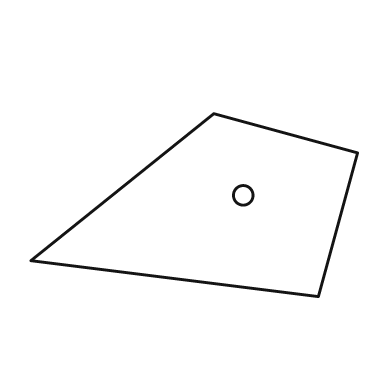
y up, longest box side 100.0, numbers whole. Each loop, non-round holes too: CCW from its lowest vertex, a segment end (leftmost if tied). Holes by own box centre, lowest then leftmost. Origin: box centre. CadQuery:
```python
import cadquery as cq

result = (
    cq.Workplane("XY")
    .moveTo(38.0, -28.0)
    .lineTo(50.0, 16.0)
    .lineTo(6.0, 28.0)
    .lineTo(-50.0, -17.0)
    .close()
    .moveTo(15.0, 3.0)
    .circle(3.0)
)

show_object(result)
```